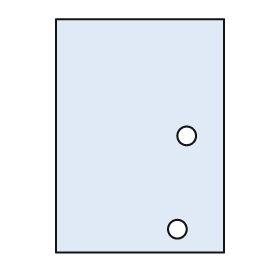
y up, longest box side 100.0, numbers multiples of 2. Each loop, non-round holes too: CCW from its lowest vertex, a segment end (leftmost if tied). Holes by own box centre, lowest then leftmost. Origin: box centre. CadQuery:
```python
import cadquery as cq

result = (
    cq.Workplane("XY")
    .moveTo(-36.0, -50.0)
    .lineTo(36.0, -50.0)
    .lineTo(36.0, 50.0)
    .lineTo(-36.0, 50.0)
    .close()
    .moveTo(16.0, -40.0)
    .circle(4.0)
    .moveTo(20.0, 0.0)
    .circle(4.0)
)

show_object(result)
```